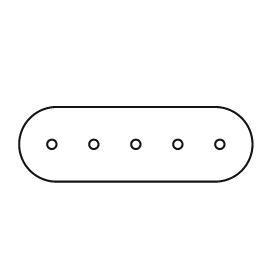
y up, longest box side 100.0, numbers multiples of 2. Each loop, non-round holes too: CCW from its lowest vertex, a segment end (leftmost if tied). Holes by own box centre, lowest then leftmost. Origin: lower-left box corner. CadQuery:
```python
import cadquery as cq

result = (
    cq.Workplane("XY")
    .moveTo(16.0, 0.0)
    .lineTo(84.0, 0.0)
    .threePointArc((100.0, 16.0), (84.0, 32.0))
    .lineTo(16.0, 32.0)
    .threePointArc((0.0, 16.0), (16.0, 0.0))
    .close()
    .moveTo(14.0, 16.0)
    .circle(2.0)
    .moveTo(32.0, 16.0)
    .circle(2.0)
    .moveTo(50.0, 16.0)
    .circle(2.0)
    .moveTo(68.0, 16.0)
    .circle(2.0)
    .moveTo(86.0, 16.0)
    .circle(2.0)
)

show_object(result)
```